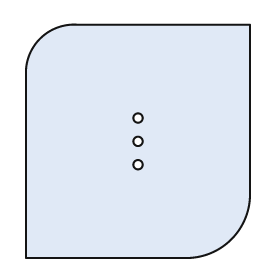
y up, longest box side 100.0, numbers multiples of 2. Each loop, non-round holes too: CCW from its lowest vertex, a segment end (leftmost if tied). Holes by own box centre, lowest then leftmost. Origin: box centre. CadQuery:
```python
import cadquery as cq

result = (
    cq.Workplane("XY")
    .moveTo(-48.0, -50.0)
    .lineTo(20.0, -50.0)
    .threePointArc((40.0, -42.0), (48.0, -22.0))
    .lineTo(48.0, 50.0)
    .lineTo(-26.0, 50.0)
    .threePointArc((-42.0, 44.0), (-48.0, 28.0))
    .close()
    .moveTo(0.0, -10.0)
    .circle(2.0)
    .moveTo(0.0, 0.0)
    .circle(2.0)
    .moveTo(0.0, 10.0)
    .circle(2.0)
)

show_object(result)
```